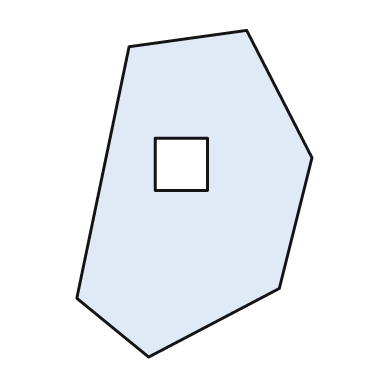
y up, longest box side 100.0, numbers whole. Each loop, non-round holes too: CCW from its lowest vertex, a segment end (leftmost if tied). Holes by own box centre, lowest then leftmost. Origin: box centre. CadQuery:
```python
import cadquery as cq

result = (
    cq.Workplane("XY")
    .moveTo(-14.0, -50.0)
    .lineTo(26.0, -29.0)
    .lineTo(36.0, 11.0)
    .lineTo(16.0, 50.0)
    .lineTo(-20.0, 45.0)
    .lineTo(-36.0, -32.0)
    .close()
    .moveTo(-12.0, 1.0)
    .lineTo(4.0, 1.0)
    .lineTo(4.0, 17.0)
    .lineTo(-12.0, 17.0)
    .close()
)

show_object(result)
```